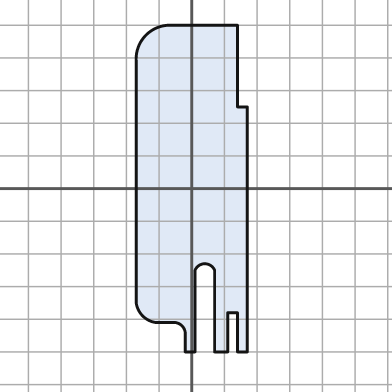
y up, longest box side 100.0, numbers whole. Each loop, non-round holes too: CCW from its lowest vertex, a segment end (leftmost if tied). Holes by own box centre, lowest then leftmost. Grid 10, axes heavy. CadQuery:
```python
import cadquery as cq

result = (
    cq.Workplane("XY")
    .moveTo(-2.0, -50.0)
    .lineTo(1.0, -50.0)
    .lineTo(1.0, -25.0)
    .threePointArc((4.0, -23.0), (7.0, -25.0))
    .lineTo(7.0, -50.0)
    .lineTo(11.0, -50.0)
    .lineTo(11.0, -38.0)
    .lineTo(14.0, -38.0)
    .lineTo(14.0, -50.0)
    .lineTo(17.0, -50.0)
    .lineTo(17.0, 25.0)
    .lineTo(14.0, 25.0)
    .lineTo(14.0, 50.0)
    .lineTo(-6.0, 50.0)
    .threePointArc((-14.0, 47.0), (-17.0, 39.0))
    .lineTo(-17.0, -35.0)
    .threePointArc((-15.0, -39.0), (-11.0, -41.0))
    .lineTo(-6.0, -41.0)
    .threePointArc((-3.0, -42.0), (-2.0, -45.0))
    .close()
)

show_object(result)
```